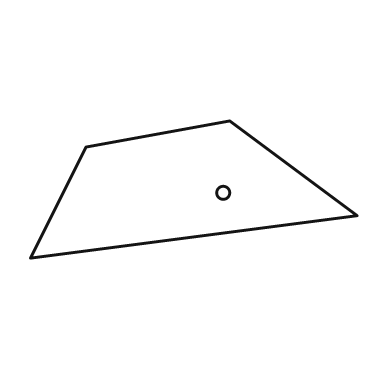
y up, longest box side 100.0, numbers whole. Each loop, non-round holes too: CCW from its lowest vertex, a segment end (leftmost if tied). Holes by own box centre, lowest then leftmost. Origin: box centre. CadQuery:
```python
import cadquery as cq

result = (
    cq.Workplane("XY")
    .moveTo(-50.0, -21.0)
    .lineTo(50.0, -8.0)
    .lineTo(11.0, 21.0)
    .lineTo(-33.0, 13.0)
    .close()
    .moveTo(9.0, -1.0)
    .circle(2.0)
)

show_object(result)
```